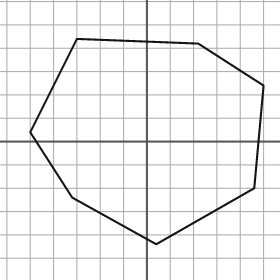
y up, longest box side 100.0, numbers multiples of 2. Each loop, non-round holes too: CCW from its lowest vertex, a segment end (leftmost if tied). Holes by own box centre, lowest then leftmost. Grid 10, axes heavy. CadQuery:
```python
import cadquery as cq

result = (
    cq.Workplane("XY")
    .moveTo(4.0, -44.0)
    .lineTo(46.0, -20.0)
    .lineTo(50.0, 24.0)
    .lineTo(22.0, 42.0)
    .lineTo(-30.0, 44.0)
    .lineTo(-50.0, 4.0)
    .lineTo(-32.0, -24.0)
    .close()
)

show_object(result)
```